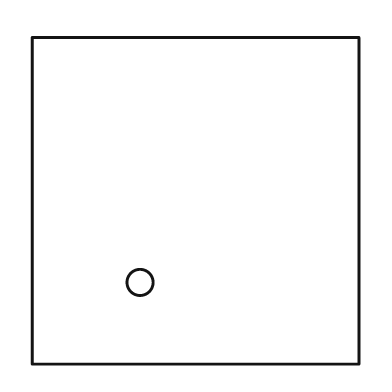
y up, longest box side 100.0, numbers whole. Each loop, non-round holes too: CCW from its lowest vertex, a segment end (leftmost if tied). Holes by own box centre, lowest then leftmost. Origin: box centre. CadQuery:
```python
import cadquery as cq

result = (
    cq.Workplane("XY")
    .moveTo(-50.0, -50.0)
    .lineTo(50.0, -50.0)
    .lineTo(50.0, 50.0)
    .lineTo(-50.0, 50.0)
    .close()
    .moveTo(-17.0, -25.0)
    .circle(4.0)
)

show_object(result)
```